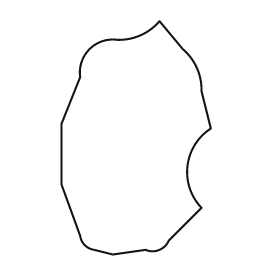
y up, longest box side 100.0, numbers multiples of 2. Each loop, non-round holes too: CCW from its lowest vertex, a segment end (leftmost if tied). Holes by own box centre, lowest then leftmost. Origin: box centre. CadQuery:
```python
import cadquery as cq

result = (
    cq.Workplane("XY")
    .moveTo(-10.0, -50.0)
    .lineTo(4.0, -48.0)
    .threePointArc((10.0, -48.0), (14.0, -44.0))
    .lineTo(28.0, -30.0)
    .threePointArc((22.0, -12.0), (32.0, 4.0))
    .lineTo(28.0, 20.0)
    .threePointArc((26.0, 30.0), (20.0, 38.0))
    .lineTo(10.0, 50.0)
    .threePointArc((2.0, 44.0), (-8.0, 42.0))
    .threePointArc((-20.0, 38.0), (-24.0, 26.0))
    .lineTo(-32.0, 6.0)
    .lineTo(-32.0, -20.0)
    .lineTo(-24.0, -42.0)
    .threePointArc((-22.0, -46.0), (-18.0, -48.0))
    .close()
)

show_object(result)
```